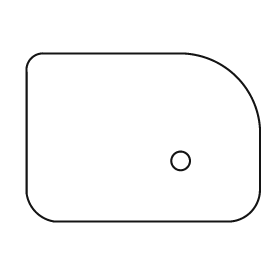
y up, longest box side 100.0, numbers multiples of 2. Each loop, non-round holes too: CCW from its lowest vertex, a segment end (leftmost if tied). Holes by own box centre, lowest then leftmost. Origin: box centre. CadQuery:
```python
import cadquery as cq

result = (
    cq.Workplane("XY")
    .moveTo(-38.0, -36.0)
    .lineTo(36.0, -36.0)
    .threePointArc((46.0, -32.0), (50.0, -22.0))
    .lineTo(50.0, 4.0)
    .threePointArc((40.0, 26.0), (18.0, 36.0))
    .lineTo(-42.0, 36.0)
    .threePointArc((-48.0, 34.0), (-50.0, 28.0))
    .lineTo(-50.0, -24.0)
    .threePointArc((-46.0, -32.0), (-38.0, -36.0))
    .close()
    .moveTo(16.0, -10.0)
    .circle(4.0)
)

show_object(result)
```